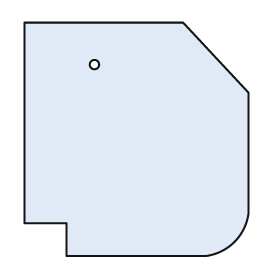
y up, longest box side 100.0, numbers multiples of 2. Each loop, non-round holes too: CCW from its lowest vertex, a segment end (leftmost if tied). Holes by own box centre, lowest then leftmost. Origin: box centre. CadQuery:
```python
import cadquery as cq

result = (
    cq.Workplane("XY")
    .moveTo(-30.0, -50.0)
    .lineTo(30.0, -50.0)
    .threePointArc((42.0, -44.0), (48.0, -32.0))
    .lineTo(48.0, 20.0)
    .lineTo(20.0, 50.0)
    .lineTo(-48.0, 50.0)
    .lineTo(-48.0, -36.0)
    .lineTo(-30.0, -36.0)
    .close()
    .moveTo(-18.0, 32.0)
    .circle(2.0)
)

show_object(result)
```